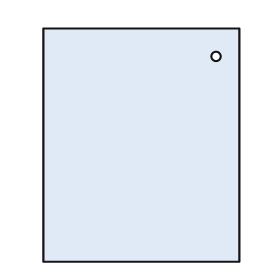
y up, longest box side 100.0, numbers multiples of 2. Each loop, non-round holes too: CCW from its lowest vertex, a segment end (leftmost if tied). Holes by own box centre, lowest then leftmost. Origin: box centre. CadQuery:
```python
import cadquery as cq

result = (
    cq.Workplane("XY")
    .moveTo(-42.0, -50.0)
    .lineTo(42.0, -50.0)
    .lineTo(42.0, 50.0)
    .lineTo(-42.0, 50.0)
    .close()
    .moveTo(32.0, 38.0)
    .circle(2.0)
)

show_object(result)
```